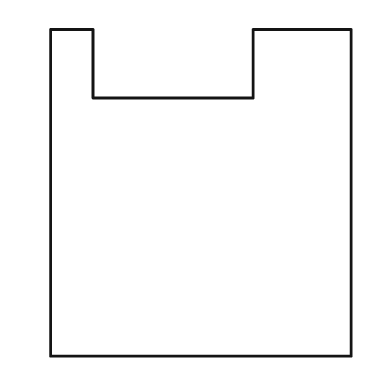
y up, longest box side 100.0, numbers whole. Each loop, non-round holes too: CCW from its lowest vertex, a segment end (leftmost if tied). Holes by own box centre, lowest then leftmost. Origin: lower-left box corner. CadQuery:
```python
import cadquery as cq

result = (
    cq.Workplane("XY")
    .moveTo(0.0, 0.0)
    .lineTo(92.0, 0.0)
    .lineTo(92.0, 100.0)
    .lineTo(62.0, 100.0)
    .lineTo(62.0, 79.0)
    .lineTo(13.0, 79.0)
    .lineTo(13.0, 100.0)
    .lineTo(0.0, 100.0)
    .close()
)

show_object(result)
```